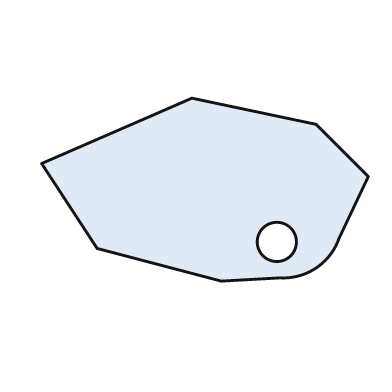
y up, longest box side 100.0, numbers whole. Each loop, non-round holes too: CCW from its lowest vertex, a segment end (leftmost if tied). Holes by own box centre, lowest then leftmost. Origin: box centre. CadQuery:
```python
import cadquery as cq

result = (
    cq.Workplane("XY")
    .moveTo(5.0, -28.0)
    .lineTo(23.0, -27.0)
    .threePointArc((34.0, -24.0), (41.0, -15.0))
    .lineTo(50.0, 4.0)
    .lineTo(34.0, 20.0)
    .lineTo(-4.0, 28.0)
    .lineTo(-50.0, 8.0)
    .lineTo(-33.0, -18.0)
    .close()
    .moveTo(22.0, -16.0)
    .circle(6.0)
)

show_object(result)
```